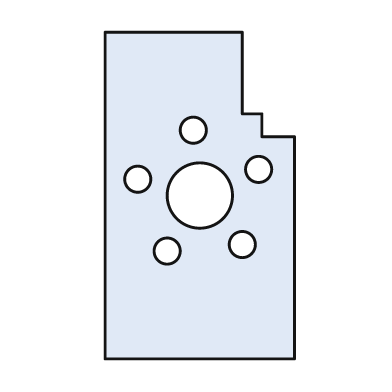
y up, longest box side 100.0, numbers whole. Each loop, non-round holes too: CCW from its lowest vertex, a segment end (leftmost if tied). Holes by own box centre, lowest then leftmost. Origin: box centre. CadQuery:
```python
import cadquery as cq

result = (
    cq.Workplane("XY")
    .moveTo(-29.0, -50.0)
    .lineTo(29.0, -50.0)
    .lineTo(29.0, 18.0)
    .lineTo(19.0, 18.0)
    .lineTo(19.0, 25.0)
    .lineTo(13.0, 25.0)
    .lineTo(13.0, 50.0)
    .lineTo(-29.0, 50.0)
    .close()
    .moveTo(-10.0, -17.0)
    .circle(4.0)
    .moveTo(13.0, -15.0)
    .circle(4.0)
    .moveTo(0.0, 0.0)
    .circle(10.0)
    .moveTo(-19.0, 5.0)
    .circle(4.0)
    .moveTo(18.0, 8.0)
    .circle(4.0)
    .moveTo(-2.0, 20.0)
    .circle(4.0)
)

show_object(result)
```